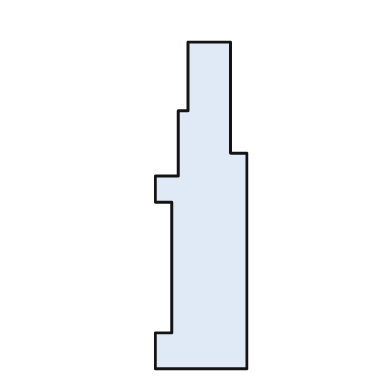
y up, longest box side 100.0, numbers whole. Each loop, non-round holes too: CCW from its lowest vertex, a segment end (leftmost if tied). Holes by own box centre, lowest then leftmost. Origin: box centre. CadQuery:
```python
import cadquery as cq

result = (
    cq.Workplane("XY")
    .moveTo(-14.0, -50.0)
    .lineTo(14.0, -50.0)
    .lineTo(14.0, 16.0)
    .lineTo(9.0, 16.0)
    .lineTo(9.0, 50.0)
    .lineTo(-4.0, 50.0)
    .lineTo(-4.0, 29.0)
    .lineTo(-7.0, 29.0)
    .lineTo(-7.0, 9.0)
    .lineTo(-14.0, 9.0)
    .lineTo(-14.0, 1.0)
    .lineTo(-9.0, 1.0)
    .lineTo(-9.0, -39.0)
    .lineTo(-14.0, -39.0)
    .close()
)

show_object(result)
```